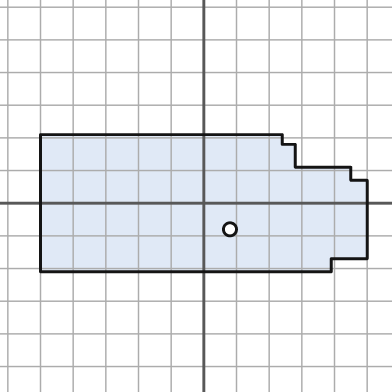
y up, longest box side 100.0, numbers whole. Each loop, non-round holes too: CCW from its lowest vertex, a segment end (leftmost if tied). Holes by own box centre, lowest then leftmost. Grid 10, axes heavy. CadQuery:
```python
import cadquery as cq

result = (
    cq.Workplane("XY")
    .moveTo(-50.0, -21.0)
    .lineTo(39.0, -21.0)
    .lineTo(39.0, -17.0)
    .lineTo(50.0, -17.0)
    .lineTo(50.0, 7.0)
    .lineTo(45.0, 7.0)
    .lineTo(45.0, 11.0)
    .lineTo(28.0, 11.0)
    .lineTo(28.0, 18.0)
    .lineTo(24.0, 18.0)
    .lineTo(24.0, 21.0)
    .lineTo(-50.0, 21.0)
    .close()
    .moveTo(8.0, -8.0)
    .circle(2.0)
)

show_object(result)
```